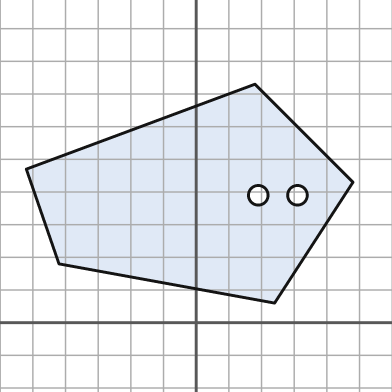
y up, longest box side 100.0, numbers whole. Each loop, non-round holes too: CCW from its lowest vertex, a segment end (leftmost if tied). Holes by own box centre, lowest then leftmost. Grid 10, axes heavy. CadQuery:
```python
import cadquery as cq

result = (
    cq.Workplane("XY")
    .moveTo(24.0, 6.0)
    .lineTo(48.0, 43.0)
    .lineTo(18.0, 73.0)
    .lineTo(-52.0, 47.0)
    .lineTo(-42.0, 18.0)
    .close()
    .moveTo(19.0, 39.0)
    .circle(3.0)
    .moveTo(31.0, 39.0)
    .circle(3.0)
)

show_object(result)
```